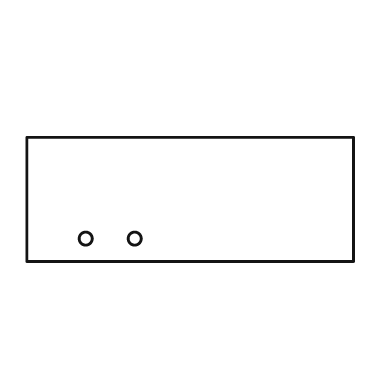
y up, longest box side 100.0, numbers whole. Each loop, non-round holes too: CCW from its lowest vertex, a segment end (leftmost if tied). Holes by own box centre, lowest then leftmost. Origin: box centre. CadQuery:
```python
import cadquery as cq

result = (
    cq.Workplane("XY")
    .moveTo(-50.0, -19.0)
    .lineTo(50.0, -19.0)
    .lineTo(50.0, 19.0)
    .lineTo(-50.0, 19.0)
    .close()
    .moveTo(-32.0, -12.0)
    .circle(2.0)
    .moveTo(-17.0, -12.0)
    .circle(2.0)
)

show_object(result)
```